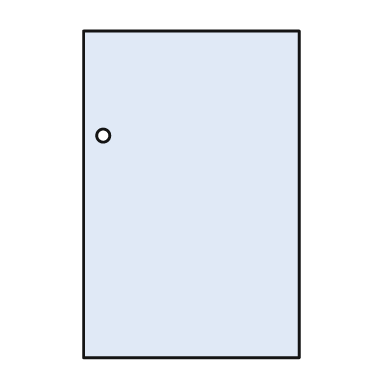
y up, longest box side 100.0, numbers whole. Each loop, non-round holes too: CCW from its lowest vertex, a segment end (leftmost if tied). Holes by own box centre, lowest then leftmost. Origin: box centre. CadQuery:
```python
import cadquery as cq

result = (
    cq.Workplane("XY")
    .moveTo(-33.0, -50.0)
    .lineTo(33.0, -50.0)
    .lineTo(33.0, 50.0)
    .lineTo(-33.0, 50.0)
    .close()
    .moveTo(-27.0, 18.0)
    .circle(2.0)
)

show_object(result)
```